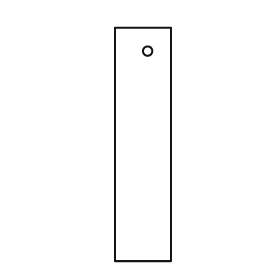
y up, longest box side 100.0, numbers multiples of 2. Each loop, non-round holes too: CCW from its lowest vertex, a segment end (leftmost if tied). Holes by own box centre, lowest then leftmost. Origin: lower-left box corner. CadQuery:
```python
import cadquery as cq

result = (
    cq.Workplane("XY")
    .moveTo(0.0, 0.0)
    .lineTo(24.0, 0.0)
    .lineTo(24.0, 100.0)
    .lineTo(0.0, 100.0)
    .close()
    .moveTo(14.0, 90.0)
    .circle(2.0)
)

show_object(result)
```